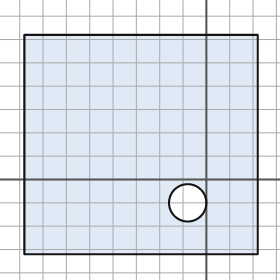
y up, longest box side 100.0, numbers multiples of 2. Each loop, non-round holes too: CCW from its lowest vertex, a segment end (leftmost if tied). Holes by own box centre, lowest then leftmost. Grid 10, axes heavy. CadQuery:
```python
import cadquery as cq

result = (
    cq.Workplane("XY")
    .moveTo(-78.0, -32.0)
    .lineTo(22.0, -32.0)
    .lineTo(22.0, 62.0)
    .lineTo(-78.0, 62.0)
    .close()
    .moveTo(-8.0, -10.0)
    .circle(8.0)
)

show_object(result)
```